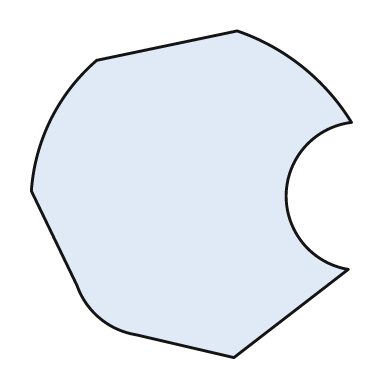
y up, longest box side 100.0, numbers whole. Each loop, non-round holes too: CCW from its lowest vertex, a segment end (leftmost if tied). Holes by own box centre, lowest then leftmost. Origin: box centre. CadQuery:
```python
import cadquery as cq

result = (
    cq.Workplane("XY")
    .moveTo(13.0, -50.0)
    .lineTo(48.0, -23.0)
    .threePointArc((29.0, 0.0), (49.0, 22.0))
    .threePointArc((34.0, 39.0), (14.0, 50.0))
    .lineTo(-29.0, 41.0)
    .threePointArc((-43.0, 23.0), (-49.0, 1.0))
    .lineTo(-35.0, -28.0)
    .threePointArc((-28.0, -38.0), (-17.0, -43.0))
    .close()
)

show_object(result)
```